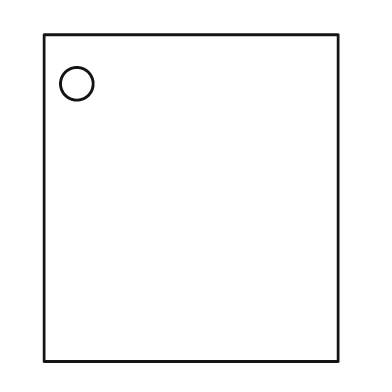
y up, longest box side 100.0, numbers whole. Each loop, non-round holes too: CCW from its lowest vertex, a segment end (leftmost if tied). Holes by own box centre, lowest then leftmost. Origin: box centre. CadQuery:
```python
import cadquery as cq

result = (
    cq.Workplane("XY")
    .moveTo(-45.0, -50.0)
    .lineTo(45.0, -50.0)
    .lineTo(45.0, 50.0)
    .lineTo(-45.0, 50.0)
    .close()
    .moveTo(-35.0, 35.0)
    .circle(5.0)
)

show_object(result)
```